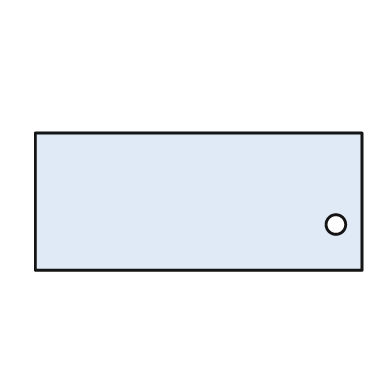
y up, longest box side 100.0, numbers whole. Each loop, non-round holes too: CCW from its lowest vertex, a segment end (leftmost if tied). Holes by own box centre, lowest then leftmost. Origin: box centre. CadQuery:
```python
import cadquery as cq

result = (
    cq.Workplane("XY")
    .moveTo(-50.0, -21.0)
    .lineTo(50.0, -21.0)
    .lineTo(50.0, 21.0)
    .lineTo(-50.0, 21.0)
    .close()
    .moveTo(42.0, -7.0)
    .circle(3.0)
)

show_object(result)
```